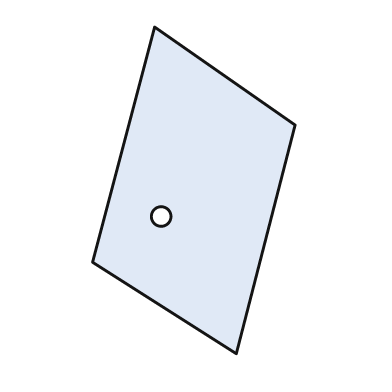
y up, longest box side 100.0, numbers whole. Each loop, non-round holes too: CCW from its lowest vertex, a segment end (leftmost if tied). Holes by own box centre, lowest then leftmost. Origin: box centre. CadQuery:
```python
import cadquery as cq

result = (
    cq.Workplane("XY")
    .moveTo(13.0, -50.0)
    .lineTo(31.0, 20.0)
    .lineTo(-12.0, 50.0)
    .lineTo(-31.0, -22.0)
    .close()
    .moveTo(-10.0, -8.0)
    .circle(3.0)
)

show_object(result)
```